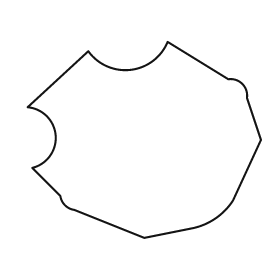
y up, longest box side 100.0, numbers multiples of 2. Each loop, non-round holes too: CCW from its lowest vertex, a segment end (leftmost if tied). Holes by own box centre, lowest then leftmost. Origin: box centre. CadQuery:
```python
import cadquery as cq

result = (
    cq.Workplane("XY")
    .moveTo(0.0, -42.0)
    .lineTo(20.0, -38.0)
    .threePointArc((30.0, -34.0), (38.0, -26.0))
    .lineTo(50.0, 0.0)
    .lineTo(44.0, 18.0)
    .threePointArc((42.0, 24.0), (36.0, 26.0))
    .lineTo(10.0, 42.0)
    .threePointArc((-6.0, 30.0), (-24.0, 38.0))
    .lineTo(-50.0, 14.0)
    .threePointArc((-38.0, 2.0), (-48.0, -12.0))
    .lineTo(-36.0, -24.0)
    .threePointArc((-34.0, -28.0), (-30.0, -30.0))
    .close()
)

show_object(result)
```